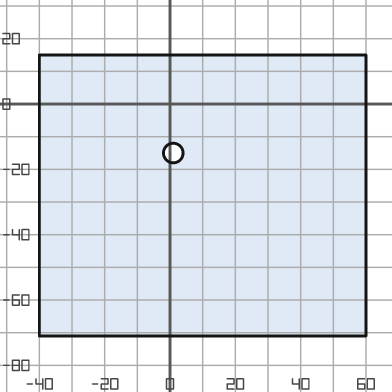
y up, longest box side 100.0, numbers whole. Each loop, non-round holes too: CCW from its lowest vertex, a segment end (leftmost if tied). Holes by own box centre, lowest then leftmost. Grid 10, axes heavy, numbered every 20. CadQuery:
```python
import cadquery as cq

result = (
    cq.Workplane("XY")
    .moveTo(-40.0, -71.0)
    .lineTo(60.0, -71.0)
    .lineTo(60.0, 15.0)
    .lineTo(-40.0, 15.0)
    .close()
    .moveTo(1.0, -15.0)
    .circle(3.0)
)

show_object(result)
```